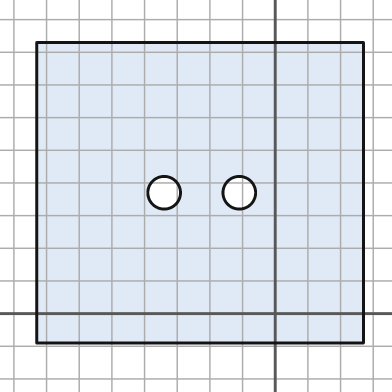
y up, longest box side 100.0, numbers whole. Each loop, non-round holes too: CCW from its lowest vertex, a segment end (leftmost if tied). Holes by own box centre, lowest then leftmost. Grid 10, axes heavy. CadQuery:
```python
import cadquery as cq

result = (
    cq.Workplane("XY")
    .moveTo(-73.0, -9.0)
    .lineTo(27.0, -9.0)
    .lineTo(27.0, 83.0)
    .lineTo(-73.0, 83.0)
    .close()
    .moveTo(-34.0, 37.0)
    .circle(5.0)
    .moveTo(-11.0, 37.0)
    .circle(5.0)
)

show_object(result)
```